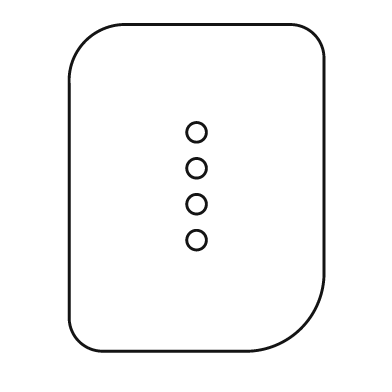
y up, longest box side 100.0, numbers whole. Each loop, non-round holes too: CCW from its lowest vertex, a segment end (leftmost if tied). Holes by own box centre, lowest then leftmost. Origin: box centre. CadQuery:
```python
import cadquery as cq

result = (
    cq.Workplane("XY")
    .moveTo(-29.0, -50.0)
    .lineTo(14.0, -50.0)
    .threePointArc((32.0, -43.0), (39.0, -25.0))
    .lineTo(39.0, 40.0)
    .threePointArc((36.0, 47.0), (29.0, 50.0))
    .lineTo(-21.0, 50.0)
    .threePointArc((-34.0, 45.0), (-39.0, 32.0))
    .lineTo(-39.0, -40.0)
    .threePointArc((-36.0, -47.0), (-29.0, -50.0))
    .close()
    .moveTo(0.0, -16.0)
    .circle(3.0)
    .moveTo(0.0, -5.0)
    .circle(3.0)
    .moveTo(0.0, 6.0)
    .circle(3.0)
    .moveTo(0.0, 17.0)
    .circle(3.0)
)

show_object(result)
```